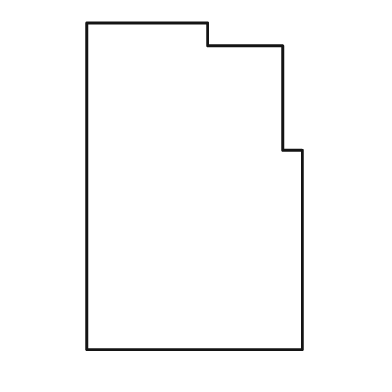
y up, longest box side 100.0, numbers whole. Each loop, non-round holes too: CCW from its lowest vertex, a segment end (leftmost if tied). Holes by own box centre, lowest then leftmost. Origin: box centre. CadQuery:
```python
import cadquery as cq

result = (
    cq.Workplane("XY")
    .moveTo(-33.0, -50.0)
    .lineTo(33.0, -50.0)
    .lineTo(33.0, 11.0)
    .lineTo(27.0, 11.0)
    .lineTo(27.0, 43.0)
    .lineTo(4.0, 43.0)
    .lineTo(4.0, 50.0)
    .lineTo(-33.0, 50.0)
    .close()
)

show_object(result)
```